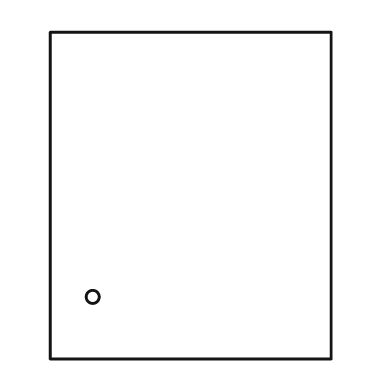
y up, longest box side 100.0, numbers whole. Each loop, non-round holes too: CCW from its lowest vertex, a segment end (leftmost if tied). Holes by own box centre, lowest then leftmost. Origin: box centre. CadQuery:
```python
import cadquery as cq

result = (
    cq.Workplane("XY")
    .moveTo(-43.0, -50.0)
    .lineTo(43.0, -50.0)
    .lineTo(43.0, 50.0)
    .lineTo(-43.0, 50.0)
    .close()
    .moveTo(-30.0, -31.0)
    .circle(2.0)
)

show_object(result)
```